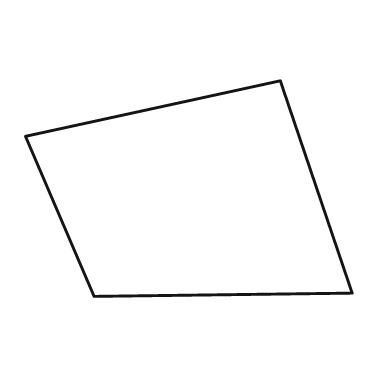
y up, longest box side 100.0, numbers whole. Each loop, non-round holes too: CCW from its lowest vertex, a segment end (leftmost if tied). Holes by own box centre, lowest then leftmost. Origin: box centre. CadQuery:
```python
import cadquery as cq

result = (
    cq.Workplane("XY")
    .moveTo(-29.0, -33.0)
    .lineTo(50.0, -32.0)
    .lineTo(28.0, 33.0)
    .lineTo(-50.0, 16.0)
    .close()
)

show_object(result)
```